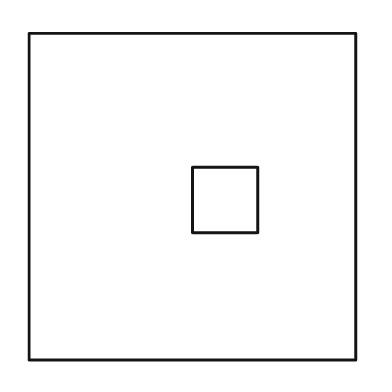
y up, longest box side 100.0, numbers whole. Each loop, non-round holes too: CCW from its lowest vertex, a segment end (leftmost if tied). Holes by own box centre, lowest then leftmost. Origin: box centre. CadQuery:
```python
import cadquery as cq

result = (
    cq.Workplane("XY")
    .moveTo(-50.0, -50.0)
    .lineTo(50.0, -50.0)
    .lineTo(50.0, 50.0)
    .lineTo(-50.0, 50.0)
    .close()
    .moveTo(0.0, -11.0)
    .lineTo(20.0, -11.0)
    .lineTo(20.0, 9.0)
    .lineTo(0.0, 9.0)
    .close()
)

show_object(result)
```